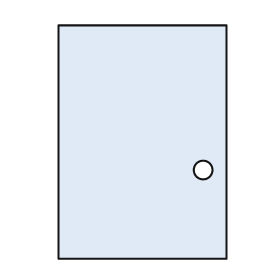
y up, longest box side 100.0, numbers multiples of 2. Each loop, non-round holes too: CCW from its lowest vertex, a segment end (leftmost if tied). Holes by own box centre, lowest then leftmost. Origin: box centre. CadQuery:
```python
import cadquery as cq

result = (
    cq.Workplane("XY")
    .moveTo(-36.0, -50.0)
    .lineTo(36.0, -50.0)
    .lineTo(36.0, 50.0)
    .lineTo(-36.0, 50.0)
    .close()
    .moveTo(26.0, -12.0)
    .circle(4.0)
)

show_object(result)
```